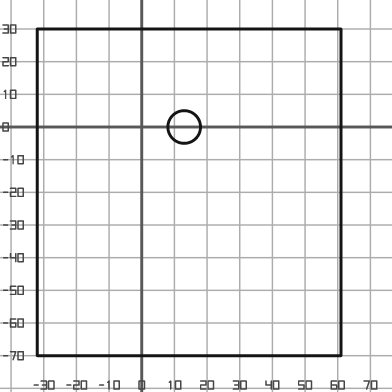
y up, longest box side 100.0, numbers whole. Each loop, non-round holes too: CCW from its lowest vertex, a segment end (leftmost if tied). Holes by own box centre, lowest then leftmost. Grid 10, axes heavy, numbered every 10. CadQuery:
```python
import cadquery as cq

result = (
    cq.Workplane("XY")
    .moveTo(-32.0, -70.0)
    .lineTo(61.0, -70.0)
    .lineTo(61.0, 30.0)
    .lineTo(-32.0, 30.0)
    .close()
    .moveTo(13.0, 0.0)
    .circle(5.0)
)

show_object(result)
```